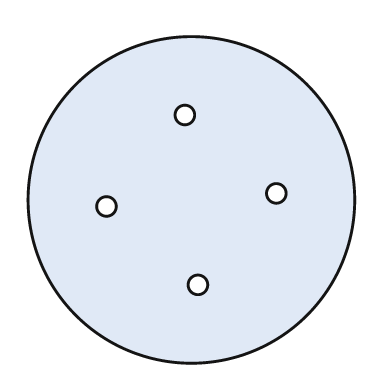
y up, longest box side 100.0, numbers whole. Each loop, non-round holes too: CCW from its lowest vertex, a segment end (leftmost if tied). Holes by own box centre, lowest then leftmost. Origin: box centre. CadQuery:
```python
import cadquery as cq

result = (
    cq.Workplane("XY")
    .moveTo(0.0, 0.0)
    .circle(50.0)
    .moveTo(2.0, -26.0)
    .circle(3.0)
    .moveTo(-26.0, -2.0)
    .circle(3.0)
    .moveTo(26.0, 2.0)
    .circle(3.0)
    .moveTo(-2.0, 26.0)
    .circle(3.0)
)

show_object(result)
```